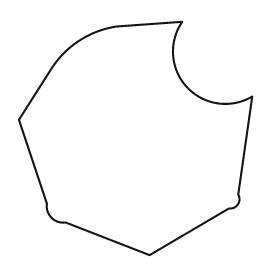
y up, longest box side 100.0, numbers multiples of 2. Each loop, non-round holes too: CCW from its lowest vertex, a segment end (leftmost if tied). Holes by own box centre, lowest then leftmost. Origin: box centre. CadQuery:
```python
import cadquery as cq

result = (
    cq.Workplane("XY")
    .moveTo(6.0, -50.0)
    .lineTo(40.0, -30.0)
    .threePointArc((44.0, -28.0), (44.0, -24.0))
    .lineTo(50.0, 18.0)
    .threePointArc((22.0, 22.0), (20.0, 50.0))
    .lineTo(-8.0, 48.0)
    .threePointArc((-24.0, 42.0), (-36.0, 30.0))
    .lineTo(-50.0, 8.0)
    .lineTo(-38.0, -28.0)
    .threePointArc((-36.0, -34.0), (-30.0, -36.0))
    .close()
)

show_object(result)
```